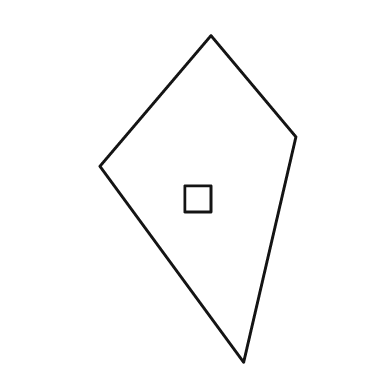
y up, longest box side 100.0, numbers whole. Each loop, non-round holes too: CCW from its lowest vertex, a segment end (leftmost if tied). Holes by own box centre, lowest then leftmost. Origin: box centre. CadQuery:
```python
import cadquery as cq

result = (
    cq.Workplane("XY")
    .moveTo(14.0, -50.0)
    .lineTo(30.0, 19.0)
    .lineTo(4.0, 50.0)
    .lineTo(-30.0, 10.0)
    .close()
    .moveTo(-4.0, -4.0)
    .lineTo(4.0, -4.0)
    .lineTo(4.0, 4.0)
    .lineTo(-4.0, 4.0)
    .close()
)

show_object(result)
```